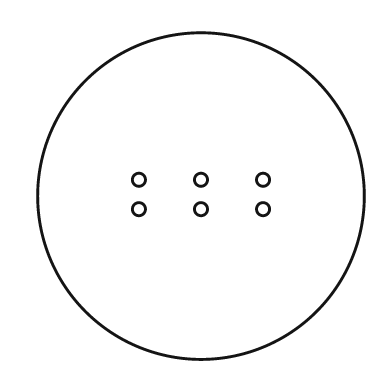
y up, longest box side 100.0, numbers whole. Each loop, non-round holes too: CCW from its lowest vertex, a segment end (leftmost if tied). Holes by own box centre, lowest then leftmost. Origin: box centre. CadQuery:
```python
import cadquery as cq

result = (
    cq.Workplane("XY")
    .moveTo(0.0, 0.0)
    .circle(50.0)
    .moveTo(-19.0, -4.0)
    .circle(2.0)
    .moveTo(0.0, -4.0)
    .circle(2.0)
    .moveTo(19.0, -4.0)
    .circle(2.0)
    .moveTo(-19.0, 5.0)
    .circle(2.0)
    .moveTo(0.0, 5.0)
    .circle(2.0)
    .moveTo(19.0, 5.0)
    .circle(2.0)
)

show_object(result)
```